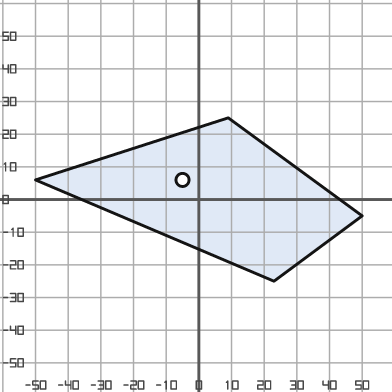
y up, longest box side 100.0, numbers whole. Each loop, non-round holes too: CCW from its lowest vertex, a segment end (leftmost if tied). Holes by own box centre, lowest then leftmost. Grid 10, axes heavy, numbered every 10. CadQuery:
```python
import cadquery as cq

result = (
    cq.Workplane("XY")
    .moveTo(23.0, -25.0)
    .lineTo(50.0, -5.0)
    .lineTo(9.0, 25.0)
    .lineTo(-50.0, 6.0)
    .close()
    .moveTo(-5.0, 6.0)
    .circle(2.0)
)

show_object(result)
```